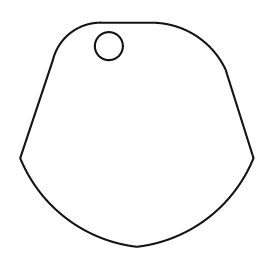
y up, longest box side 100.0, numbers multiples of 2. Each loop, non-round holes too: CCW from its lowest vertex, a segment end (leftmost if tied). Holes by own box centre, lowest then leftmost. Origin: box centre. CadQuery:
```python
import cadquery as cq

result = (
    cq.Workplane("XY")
    .moveTo(0.0, -48.0)
    .threePointArc((30.0, -36.0), (50.0, -10.0))
    .lineTo(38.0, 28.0)
    .threePointArc((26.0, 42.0), (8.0, 48.0))
    .lineTo(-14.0, 48.0)
    .threePointArc((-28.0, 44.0), (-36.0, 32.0))
    .lineTo(-50.0, -10.0)
    .threePointArc((-30.0, -36.0), (0.0, -48.0))
    .close()
    .moveTo(-12.0, 38.0)
    .circle(6.0)
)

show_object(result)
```